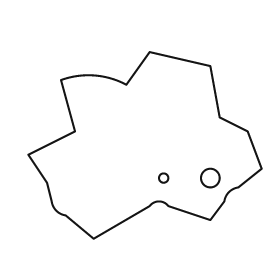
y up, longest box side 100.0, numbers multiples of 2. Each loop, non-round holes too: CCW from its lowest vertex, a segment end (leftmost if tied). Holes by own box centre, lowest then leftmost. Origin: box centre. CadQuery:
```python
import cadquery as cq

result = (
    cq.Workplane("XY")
    .moveTo(-22.0, -40.0)
    .lineTo(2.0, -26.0)
    .threePointArc((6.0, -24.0), (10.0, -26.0))
    .lineTo(28.0, -32.0)
    .lineTo(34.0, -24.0)
    .threePointArc((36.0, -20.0), (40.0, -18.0))
    .lineTo(50.0, -10.0)
    .lineTo(44.0, 6.0)
    .lineTo(32.0, 12.0)
    .lineTo(28.0, 34.0)
    .lineTo(2.0, 40.0)
    .lineTo(-8.0, 26.0)
    .threePointArc((-22.0, 30.0), (-36.0, 28.0))
    .lineTo(-30.0, 6.0)
    .lineTo(-50.0, -4.0)
    .lineTo(-42.0, -16.0)
    .lineTo(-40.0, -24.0)
    .threePointArc((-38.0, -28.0), (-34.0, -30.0))
    .close()
    .moveTo(8.0, -14.0)
    .circle(2.0)
    .moveTo(28.0, -14.0)
    .circle(4.0)
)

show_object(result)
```